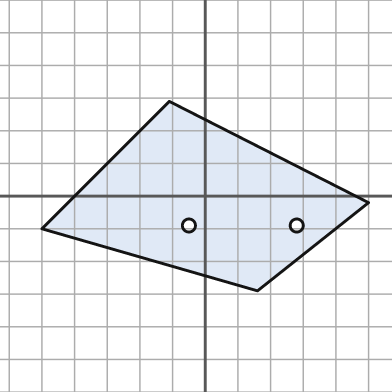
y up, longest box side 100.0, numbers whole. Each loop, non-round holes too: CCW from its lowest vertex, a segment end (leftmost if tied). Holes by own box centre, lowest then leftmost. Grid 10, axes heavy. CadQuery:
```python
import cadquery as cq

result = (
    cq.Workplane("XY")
    .moveTo(16.0, -29.0)
    .lineTo(50.0, -2.0)
    .lineTo(-11.0, 29.0)
    .lineTo(-50.0, -10.0)
    .close()
    .moveTo(-5.0, -9.0)
    .circle(2.0)
    .moveTo(28.0, -9.0)
    .circle(2.0)
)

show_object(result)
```